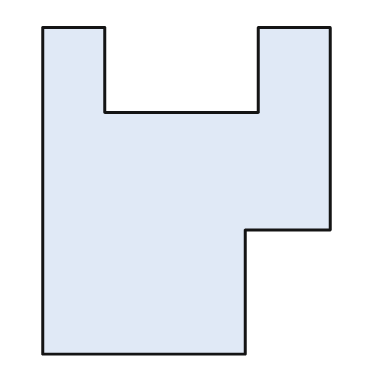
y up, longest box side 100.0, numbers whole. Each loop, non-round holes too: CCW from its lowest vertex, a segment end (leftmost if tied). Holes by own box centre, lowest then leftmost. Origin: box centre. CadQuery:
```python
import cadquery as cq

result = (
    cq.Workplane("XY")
    .moveTo(-44.0, -50.0)
    .lineTo(18.0, -50.0)
    .lineTo(18.0, -12.0)
    .lineTo(44.0, -12.0)
    .lineTo(44.0, 50.0)
    .lineTo(22.0, 50.0)
    .lineTo(22.0, 24.0)
    .lineTo(-25.0, 24.0)
    .lineTo(-25.0, 50.0)
    .lineTo(-44.0, 50.0)
    .close()
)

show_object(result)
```